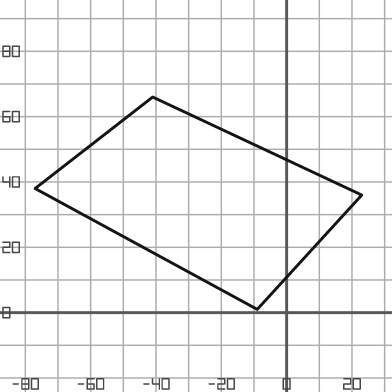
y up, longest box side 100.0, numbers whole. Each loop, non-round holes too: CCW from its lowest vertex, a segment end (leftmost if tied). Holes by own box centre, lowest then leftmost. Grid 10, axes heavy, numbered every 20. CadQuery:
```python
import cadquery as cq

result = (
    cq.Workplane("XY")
    .moveTo(-9.0, 1.0)
    .lineTo(23.0, 36.0)
    .lineTo(-41.0, 66.0)
    .lineTo(-77.0, 38.0)
    .close()
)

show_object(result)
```